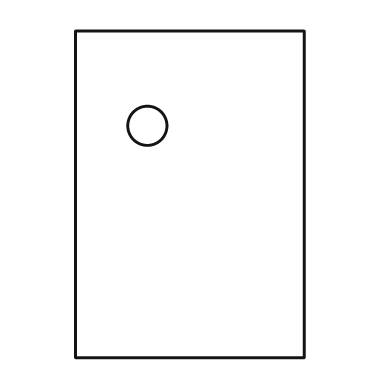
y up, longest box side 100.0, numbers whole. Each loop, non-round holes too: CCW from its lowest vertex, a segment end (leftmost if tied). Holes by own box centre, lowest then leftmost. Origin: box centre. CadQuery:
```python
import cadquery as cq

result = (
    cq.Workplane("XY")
    .moveTo(-35.0, -50.0)
    .lineTo(35.0, -50.0)
    .lineTo(35.0, 50.0)
    .lineTo(-35.0, 50.0)
    .close()
    .moveTo(-13.0, 21.0)
    .circle(6.0)
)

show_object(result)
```